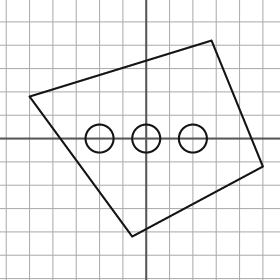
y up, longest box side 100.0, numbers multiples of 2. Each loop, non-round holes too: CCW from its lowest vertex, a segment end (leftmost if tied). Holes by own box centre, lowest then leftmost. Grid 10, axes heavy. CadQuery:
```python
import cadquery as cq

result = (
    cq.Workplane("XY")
    .moveTo(-6.0, -42.0)
    .lineTo(50.0, -12.0)
    .lineTo(28.0, 42.0)
    .lineTo(-50.0, 18.0)
    .close()
    .moveTo(-20.0, 0.0)
    .circle(6.0)
    .moveTo(0.0, 0.0)
    .circle(6.0)
    .moveTo(20.0, 0.0)
    .circle(6.0)
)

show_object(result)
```